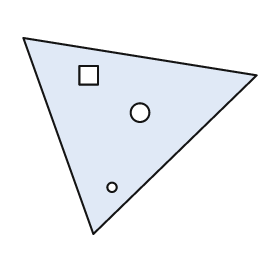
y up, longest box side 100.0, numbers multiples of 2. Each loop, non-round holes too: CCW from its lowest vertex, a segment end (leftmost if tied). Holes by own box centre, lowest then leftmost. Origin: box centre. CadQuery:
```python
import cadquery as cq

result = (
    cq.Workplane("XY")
    .moveTo(-20.0, -42.0)
    .lineTo(50.0, 26.0)
    .lineTo(-50.0, 42.0)
    .close()
    .moveTo(-12.0, -22.0)
    .circle(2.0)
    .moveTo(0.0, 10.0)
    .circle(4.0)
    .moveTo(-26.0, 22.0)
    .lineTo(-18.0, 22.0)
    .lineTo(-18.0, 30.0)
    .lineTo(-26.0, 30.0)
    .close()
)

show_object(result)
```